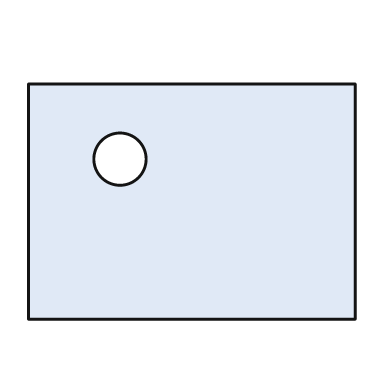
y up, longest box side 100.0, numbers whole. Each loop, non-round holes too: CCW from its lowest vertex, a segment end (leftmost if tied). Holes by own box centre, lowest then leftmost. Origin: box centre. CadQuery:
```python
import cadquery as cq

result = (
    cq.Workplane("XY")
    .moveTo(-50.0, -36.0)
    .lineTo(50.0, -36.0)
    .lineTo(50.0, 36.0)
    .lineTo(-50.0, 36.0)
    .close()
    .moveTo(-22.0, 13.0)
    .circle(8.0)
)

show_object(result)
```